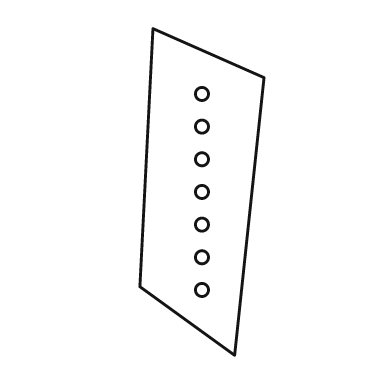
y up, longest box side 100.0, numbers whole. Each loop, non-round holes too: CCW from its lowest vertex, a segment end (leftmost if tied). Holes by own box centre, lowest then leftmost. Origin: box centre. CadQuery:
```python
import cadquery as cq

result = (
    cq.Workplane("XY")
    .moveTo(10.0, -50.0)
    .lineTo(19.0, 35.0)
    .lineTo(-15.0, 50.0)
    .lineTo(-19.0, -29.0)
    .close()
    .moveTo(0.0, -30.0)
    .circle(2.0)
    .moveTo(0.0, -20.0)
    .circle(2.0)
    .moveTo(0.0, -10.0)
    .circle(2.0)
    .moveTo(0.0, 0.0)
    .circle(2.0)
    .moveTo(0.0, 10.0)
    .circle(2.0)
    .moveTo(0.0, 20.0)
    .circle(2.0)
    .moveTo(0.0, 30.0)
    .circle(2.0)
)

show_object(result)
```